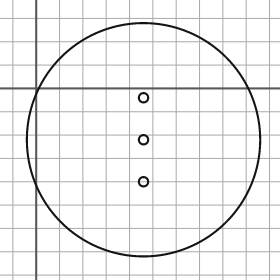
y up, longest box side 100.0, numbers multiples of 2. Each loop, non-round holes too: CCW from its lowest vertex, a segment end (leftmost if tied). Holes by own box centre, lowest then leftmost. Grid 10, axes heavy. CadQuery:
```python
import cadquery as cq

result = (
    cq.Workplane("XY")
    .moveTo(46.0, -22.0)
    .circle(50.0)
    .moveTo(46.0, -40.0)
    .circle(2.0)
    .moveTo(46.0, -22.0)
    .circle(2.0)
    .moveTo(46.0, -4.0)
    .circle(2.0)
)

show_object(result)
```